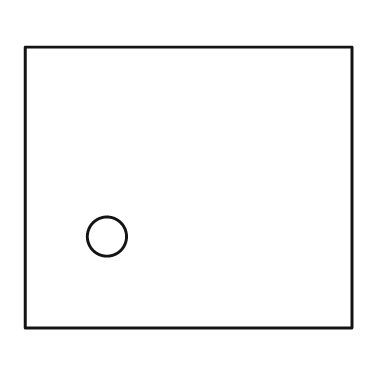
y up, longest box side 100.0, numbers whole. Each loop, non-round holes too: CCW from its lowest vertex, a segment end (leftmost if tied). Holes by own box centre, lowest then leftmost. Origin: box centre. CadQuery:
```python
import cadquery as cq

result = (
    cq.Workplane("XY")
    .moveTo(-50.0, -43.0)
    .lineTo(50.0, -43.0)
    .lineTo(50.0, 43.0)
    .lineTo(-50.0, 43.0)
    .close()
    .moveTo(-25.0, -15.0)
    .circle(6.0)
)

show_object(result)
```